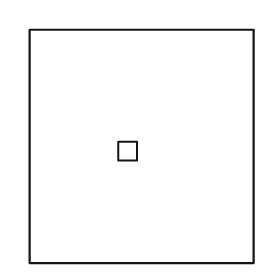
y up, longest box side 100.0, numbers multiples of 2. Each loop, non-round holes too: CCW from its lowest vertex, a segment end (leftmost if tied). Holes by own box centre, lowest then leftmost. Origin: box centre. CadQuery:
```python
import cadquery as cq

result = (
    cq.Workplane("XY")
    .moveTo(-48.0, -50.0)
    .lineTo(48.0, -50.0)
    .lineTo(48.0, 50.0)
    .lineTo(-48.0, 50.0)
    .close()
    .moveTo(-10.0, -6.0)
    .lineTo(-2.0, -6.0)
    .lineTo(-2.0, 2.0)
    .lineTo(-10.0, 2.0)
    .close()
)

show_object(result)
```